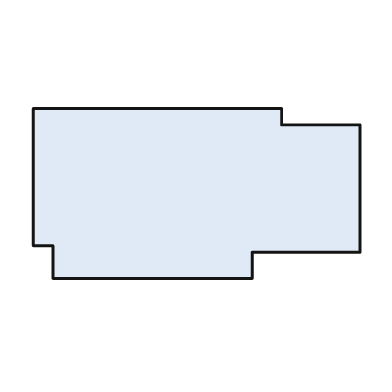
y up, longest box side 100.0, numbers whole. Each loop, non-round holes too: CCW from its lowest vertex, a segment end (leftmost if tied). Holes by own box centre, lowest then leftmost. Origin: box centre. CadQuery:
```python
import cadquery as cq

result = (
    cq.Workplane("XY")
    .moveTo(-44.0, -26.0)
    .lineTo(17.0, -26.0)
    .lineTo(17.0, -18.0)
    .lineTo(50.0, -18.0)
    .lineTo(50.0, 21.0)
    .lineTo(26.0, 21.0)
    .lineTo(26.0, 26.0)
    .lineTo(-50.0, 26.0)
    .lineTo(-50.0, -16.0)
    .lineTo(-44.0, -16.0)
    .close()
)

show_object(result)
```